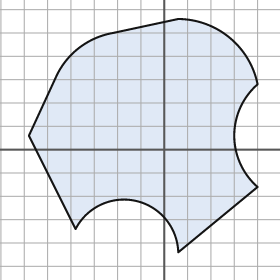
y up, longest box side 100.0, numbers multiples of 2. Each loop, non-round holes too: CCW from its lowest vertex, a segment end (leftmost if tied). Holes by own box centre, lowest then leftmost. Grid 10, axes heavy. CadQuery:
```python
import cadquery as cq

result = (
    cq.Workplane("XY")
    .moveTo(6.0, -44.0)
    .lineTo(40.0, -16.0)
    .threePointArc((30.0, 6.0), (40.0, 28.0))
    .threePointArc((28.0, 48.0), (6.0, 56.0))
    .lineTo(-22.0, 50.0)
    .threePointArc((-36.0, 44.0), (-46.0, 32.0))
    .lineTo(-58.0, 6.0)
    .lineTo(-38.0, -34.0)
    .threePointArc((-12.0, -22.0), (6.0, -44.0))
    .close()
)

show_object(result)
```